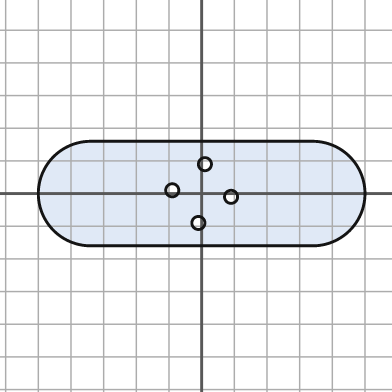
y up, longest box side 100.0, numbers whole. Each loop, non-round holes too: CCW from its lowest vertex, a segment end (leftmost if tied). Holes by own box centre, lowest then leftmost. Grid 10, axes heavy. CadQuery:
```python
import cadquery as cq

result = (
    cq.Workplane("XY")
    .moveTo(-34.0, -16.0)
    .lineTo(34.0, -16.0)
    .threePointArc((50.0, 0.0), (34.0, 16.0))
    .lineTo(-34.0, 16.0)
    .threePointArc((-50.0, 0.0), (-34.0, -16.0))
    .close()
    .moveTo(-1.0, -9.0)
    .circle(2.0)
    .moveTo(9.0, -1.0)
    .circle(2.0)
    .moveTo(-9.0, 1.0)
    .circle(2.0)
    .moveTo(1.0, 9.0)
    .circle(2.0)
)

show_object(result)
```